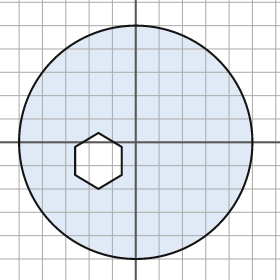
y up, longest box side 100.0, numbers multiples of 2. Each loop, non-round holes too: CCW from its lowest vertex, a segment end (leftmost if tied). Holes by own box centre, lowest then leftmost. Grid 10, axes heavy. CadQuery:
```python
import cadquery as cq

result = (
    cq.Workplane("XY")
    .moveTo(0.0, 0.0)
    .circle(50.0)
    .moveTo(-16.0, -20.0)
    .lineTo(-6.0, -14.0)
    .lineTo(-6.0, -2.0)
    .lineTo(-16.0, 4.0)
    .lineTo(-26.0, -2.0)
    .lineTo(-26.0, -14.0)
    .close()
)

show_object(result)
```